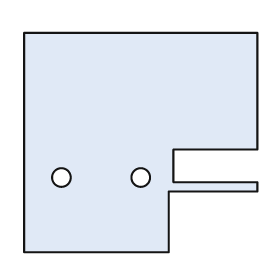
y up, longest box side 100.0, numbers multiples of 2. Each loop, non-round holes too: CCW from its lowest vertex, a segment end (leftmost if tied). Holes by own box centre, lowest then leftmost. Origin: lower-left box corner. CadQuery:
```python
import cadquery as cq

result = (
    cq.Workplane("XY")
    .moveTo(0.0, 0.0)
    .lineTo(62.0, 0.0)
    .lineTo(62.0, 26.0)
    .lineTo(100.0, 26.0)
    .lineTo(100.0, 30.0)
    .lineTo(64.0, 30.0)
    .lineTo(64.0, 44.0)
    .lineTo(100.0, 44.0)
    .lineTo(100.0, 94.0)
    .lineTo(0.0, 94.0)
    .close()
    .moveTo(16.0, 32.0)
    .circle(4.0)
    .moveTo(50.0, 32.0)
    .circle(4.0)
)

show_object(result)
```